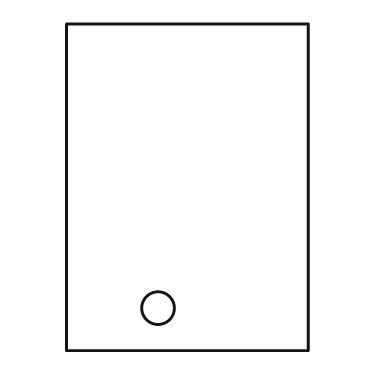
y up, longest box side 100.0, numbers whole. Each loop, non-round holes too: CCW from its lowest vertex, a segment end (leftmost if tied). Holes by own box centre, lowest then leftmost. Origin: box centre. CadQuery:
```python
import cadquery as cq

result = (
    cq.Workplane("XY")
    .moveTo(-37.0, -50.0)
    .lineTo(37.0, -50.0)
    .lineTo(37.0, 50.0)
    .lineTo(-37.0, 50.0)
    .close()
    .moveTo(-9.0, -37.0)
    .circle(5.0)
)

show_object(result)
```